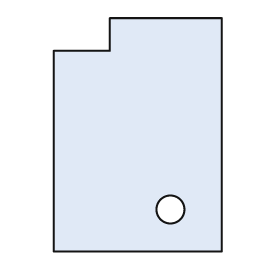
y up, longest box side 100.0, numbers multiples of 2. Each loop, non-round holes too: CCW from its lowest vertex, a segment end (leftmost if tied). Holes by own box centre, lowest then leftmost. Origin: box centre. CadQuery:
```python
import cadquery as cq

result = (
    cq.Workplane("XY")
    .moveTo(-36.0, -50.0)
    .lineTo(36.0, -50.0)
    .lineTo(36.0, 50.0)
    .lineTo(-12.0, 50.0)
    .lineTo(-12.0, 36.0)
    .lineTo(-36.0, 36.0)
    .close()
    .moveTo(14.0, -32.0)
    .circle(6.0)
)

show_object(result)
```